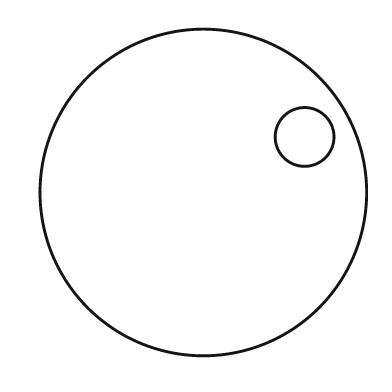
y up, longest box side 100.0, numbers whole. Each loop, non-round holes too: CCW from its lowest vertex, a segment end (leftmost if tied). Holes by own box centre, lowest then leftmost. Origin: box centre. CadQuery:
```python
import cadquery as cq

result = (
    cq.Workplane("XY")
    .moveTo(0.0, 0.0)
    .circle(50.0)
    .moveTo(31.0, 17.0)
    .circle(9.0)
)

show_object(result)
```